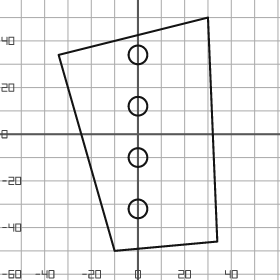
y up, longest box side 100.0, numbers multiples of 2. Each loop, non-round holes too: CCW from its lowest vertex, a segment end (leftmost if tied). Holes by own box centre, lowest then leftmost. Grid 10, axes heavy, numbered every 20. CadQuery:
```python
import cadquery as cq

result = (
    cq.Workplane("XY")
    .moveTo(-10.0, -50.0)
    .lineTo(34.0, -46.0)
    .lineTo(30.0, 50.0)
    .lineTo(-34.0, 34.0)
    .close()
    .moveTo(0.0, -32.0)
    .circle(4.0)
    .moveTo(0.0, -10.0)
    .circle(4.0)
    .moveTo(0.0, 12.0)
    .circle(4.0)
    .moveTo(0.0, 34.0)
    .circle(4.0)
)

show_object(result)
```